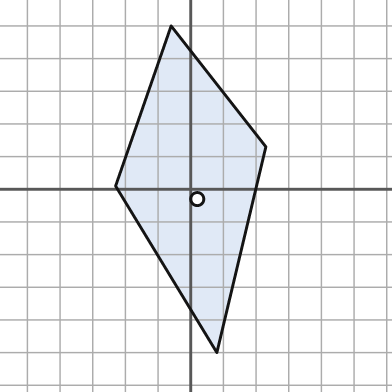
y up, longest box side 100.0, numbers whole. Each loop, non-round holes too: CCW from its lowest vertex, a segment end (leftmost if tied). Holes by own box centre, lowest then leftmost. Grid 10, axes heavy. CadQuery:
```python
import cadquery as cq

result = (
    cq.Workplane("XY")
    .moveTo(8.0, -50.0)
    .lineTo(23.0, 13.0)
    .lineTo(-6.0, 50.0)
    .lineTo(-23.0, 1.0)
    .close()
    .moveTo(2.0, -3.0)
    .circle(2.0)
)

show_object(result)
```